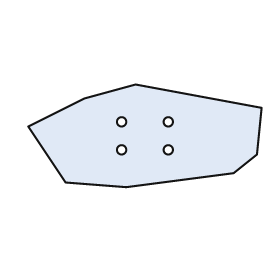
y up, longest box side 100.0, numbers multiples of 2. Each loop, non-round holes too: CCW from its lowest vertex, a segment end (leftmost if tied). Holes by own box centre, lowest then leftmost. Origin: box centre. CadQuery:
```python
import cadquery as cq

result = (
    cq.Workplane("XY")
    .moveTo(-8.0, -22.0)
    .lineTo(38.0, -16.0)
    .lineTo(48.0, -8.0)
    .lineTo(50.0, 12.0)
    .lineTo(-4.0, 22.0)
    .lineTo(-26.0, 16.0)
    .lineTo(-50.0, 4.0)
    .lineTo(-34.0, -20.0)
    .close()
    .moveTo(-10.0, -6.0)
    .circle(2.0)
    .moveTo(10.0, -6.0)
    .circle(2.0)
    .moveTo(-10.0, 6.0)
    .circle(2.0)
    .moveTo(10.0, 6.0)
    .circle(2.0)
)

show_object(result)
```